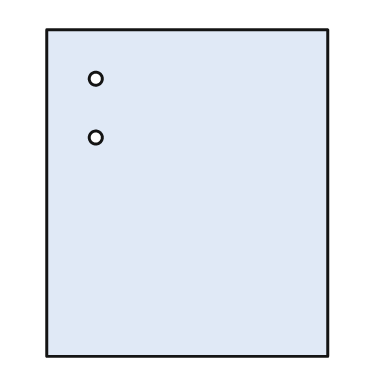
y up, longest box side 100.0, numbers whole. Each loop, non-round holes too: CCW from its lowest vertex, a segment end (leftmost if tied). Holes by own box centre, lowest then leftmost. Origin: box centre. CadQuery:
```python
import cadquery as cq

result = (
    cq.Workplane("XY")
    .moveTo(-43.0, -50.0)
    .lineTo(43.0, -50.0)
    .lineTo(43.0, 50.0)
    .lineTo(-43.0, 50.0)
    .close()
    .moveTo(-28.0, 17.0)
    .circle(2.0)
    .moveTo(-28.0, 35.0)
    .circle(2.0)
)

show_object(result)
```